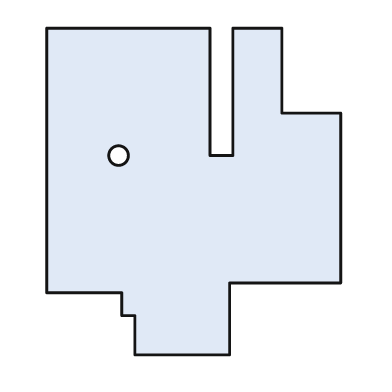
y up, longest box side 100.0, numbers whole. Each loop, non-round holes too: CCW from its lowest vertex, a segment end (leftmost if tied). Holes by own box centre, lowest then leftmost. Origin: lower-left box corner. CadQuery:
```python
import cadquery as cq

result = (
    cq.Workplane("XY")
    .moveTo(27.0, 0.0)
    .lineTo(56.0, 0.0)
    .lineTo(56.0, 22.0)
    .lineTo(90.0, 22.0)
    .lineTo(90.0, 74.0)
    .lineTo(72.0, 74.0)
    .lineTo(72.0, 100.0)
    .lineTo(57.0, 100.0)
    .lineTo(57.0, 61.0)
    .lineTo(50.0, 61.0)
    .lineTo(50.0, 100.0)
    .lineTo(0.0, 100.0)
    .lineTo(0.0, 19.0)
    .lineTo(23.0, 19.0)
    .lineTo(23.0, 12.0)
    .lineTo(27.0, 12.0)
    .close()
    .moveTo(22.0, 61.0)
    .circle(3.0)
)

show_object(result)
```